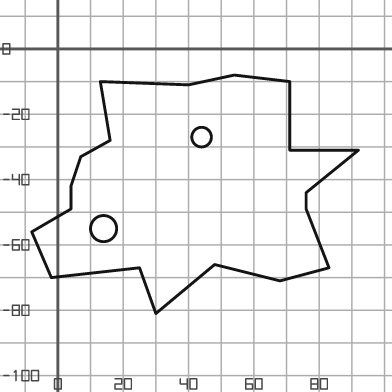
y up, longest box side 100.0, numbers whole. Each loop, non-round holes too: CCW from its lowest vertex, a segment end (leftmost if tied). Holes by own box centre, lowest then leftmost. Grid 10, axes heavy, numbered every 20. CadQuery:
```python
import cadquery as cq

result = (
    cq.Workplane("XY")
    .moveTo(30.0, -81.0)
    .lineTo(48.0, -66.0)
    .lineTo(68.0, -71.0)
    .lineTo(83.0, -67.0)
    .lineTo(76.0, -49.0)
    .lineTo(76.0, -44.0)
    .lineTo(92.0, -31.0)
    .lineTo(71.0, -31.0)
    .lineTo(71.0, -10.0)
    .lineTo(54.0, -8.0)
    .lineTo(40.0, -11.0)
    .lineTo(13.0, -10.0)
    .lineTo(16.0, -28.0)
    .lineTo(7.0, -33.0)
    .lineTo(4.0, -42.0)
    .lineTo(4.0, -49.0)
    .lineTo(-8.0, -56.0)
    .lineTo(-2.0, -70.0)
    .lineTo(25.0, -67.0)
    .close()
    .moveTo(14.0, -55.0)
    .circle(4.0)
    .moveTo(44.0, -27.0)
    .circle(3.0)
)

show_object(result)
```